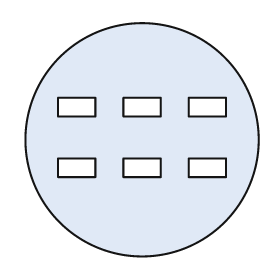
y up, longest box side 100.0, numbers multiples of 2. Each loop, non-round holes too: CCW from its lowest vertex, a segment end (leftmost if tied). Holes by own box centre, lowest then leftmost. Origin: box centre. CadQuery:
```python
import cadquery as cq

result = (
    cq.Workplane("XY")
    .moveTo(0.0, 0.0)
    .circle(50.0)
    .moveTo(-36.0, -16.0)
    .lineTo(-20.0, -16.0)
    .lineTo(-20.0, -8.0)
    .lineTo(-36.0, -8.0)
    .close()
    .moveTo(-8.0, -16.0)
    .lineTo(8.0, -16.0)
    .lineTo(8.0, -8.0)
    .lineTo(-8.0, -8.0)
    .close()
    .moveTo(20.0, -16.0)
    .lineTo(36.0, -16.0)
    .lineTo(36.0, -8.0)
    .lineTo(20.0, -8.0)
    .close()
    .moveTo(-36.0, 10.0)
    .lineTo(-20.0, 10.0)
    .lineTo(-20.0, 18.0)
    .lineTo(-36.0, 18.0)
    .close()
    .moveTo(-8.0, 10.0)
    .lineTo(8.0, 10.0)
    .lineTo(8.0, 18.0)
    .lineTo(-8.0, 18.0)
    .close()
    .moveTo(20.0, 10.0)
    .lineTo(36.0, 10.0)
    .lineTo(36.0, 18.0)
    .lineTo(20.0, 18.0)
    .close()
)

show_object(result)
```